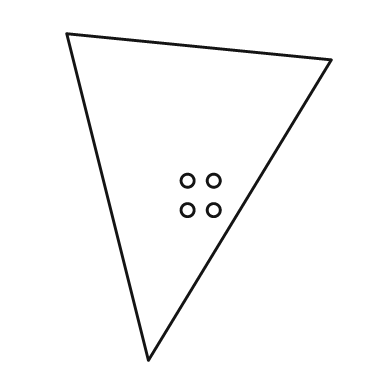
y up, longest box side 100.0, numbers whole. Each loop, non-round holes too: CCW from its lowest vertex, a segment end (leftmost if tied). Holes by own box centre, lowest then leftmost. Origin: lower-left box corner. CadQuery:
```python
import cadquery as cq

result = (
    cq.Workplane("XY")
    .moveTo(25.0, 0.0)
    .lineTo(81.0, 92.0)
    .lineTo(0.0, 100.0)
    .close()
    .moveTo(37.0, 46.0)
    .circle(2.0)
    .moveTo(45.0, 46.0)
    .circle(2.0)
    .moveTo(37.0, 55.0)
    .circle(2.0)
    .moveTo(45.0, 55.0)
    .circle(2.0)
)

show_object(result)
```